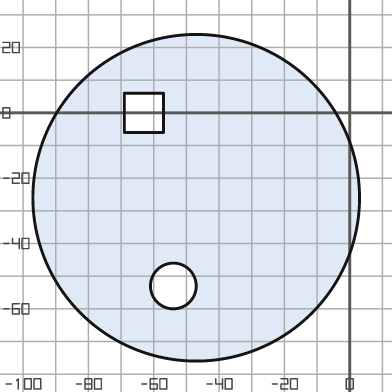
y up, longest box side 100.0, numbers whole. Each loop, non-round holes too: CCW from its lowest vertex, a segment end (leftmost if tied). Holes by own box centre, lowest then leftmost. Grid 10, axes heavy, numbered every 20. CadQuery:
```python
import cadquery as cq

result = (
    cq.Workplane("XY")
    .moveTo(-47.0, -26.0)
    .circle(50.0)
    .moveTo(-54.0, -53.0)
    .circle(7.0)
    .moveTo(-69.0, -6.0)
    .lineTo(-57.0, -6.0)
    .lineTo(-57.0, 6.0)
    .lineTo(-69.0, 6.0)
    .close()
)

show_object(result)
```